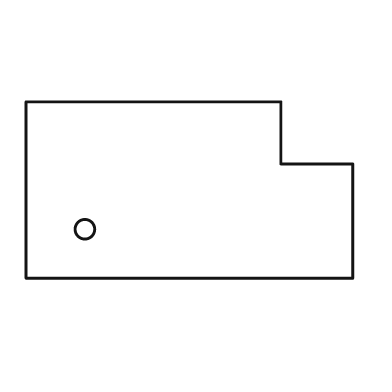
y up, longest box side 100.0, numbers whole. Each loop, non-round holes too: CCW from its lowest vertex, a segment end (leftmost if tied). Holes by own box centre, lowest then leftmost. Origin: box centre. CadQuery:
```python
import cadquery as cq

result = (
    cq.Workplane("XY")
    .moveTo(-50.0, -27.0)
    .lineTo(50.0, -27.0)
    .lineTo(50.0, 8.0)
    .lineTo(28.0, 8.0)
    .lineTo(28.0, 27.0)
    .lineTo(-50.0, 27.0)
    .close()
    .moveTo(-32.0, -12.0)
    .circle(3.0)
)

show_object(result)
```